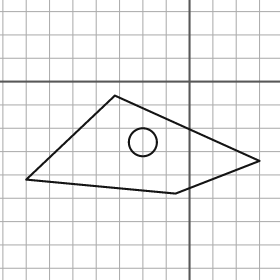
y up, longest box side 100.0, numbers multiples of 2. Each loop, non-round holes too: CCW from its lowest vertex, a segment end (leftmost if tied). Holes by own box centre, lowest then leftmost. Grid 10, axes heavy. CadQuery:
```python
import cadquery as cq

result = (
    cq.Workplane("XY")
    .moveTo(-6.0, -48.0)
    .lineTo(30.0, -34.0)
    .lineTo(-32.0, -6.0)
    .lineTo(-70.0, -42.0)
    .close()
    .moveTo(-20.0, -26.0)
    .circle(6.0)
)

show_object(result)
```